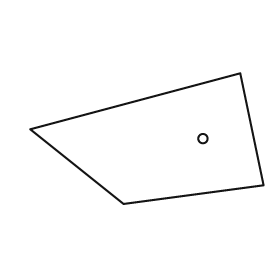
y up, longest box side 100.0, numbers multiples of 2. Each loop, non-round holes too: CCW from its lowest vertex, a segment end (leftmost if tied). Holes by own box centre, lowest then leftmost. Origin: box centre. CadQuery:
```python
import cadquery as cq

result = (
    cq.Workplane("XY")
    .moveTo(-10.0, -28.0)
    .lineTo(50.0, -20.0)
    .lineTo(40.0, 28.0)
    .lineTo(-50.0, 4.0)
    .close()
    .moveTo(24.0, 0.0)
    .circle(2.0)
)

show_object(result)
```